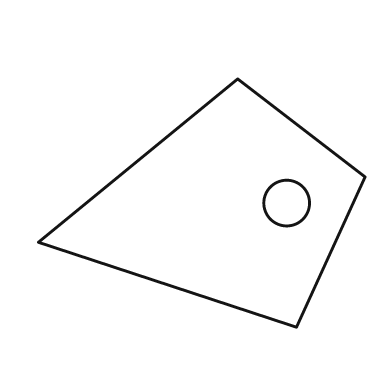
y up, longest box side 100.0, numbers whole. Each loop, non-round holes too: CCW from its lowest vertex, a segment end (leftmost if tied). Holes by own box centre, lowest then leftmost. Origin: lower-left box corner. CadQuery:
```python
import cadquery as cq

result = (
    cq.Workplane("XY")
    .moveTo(79.0, 0.0)
    .lineTo(100.0, 46.0)
    .lineTo(61.0, 76.0)
    .lineTo(0.0, 26.0)
    .close()
    .moveTo(76.0, 38.0)
    .circle(7.0)
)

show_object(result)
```